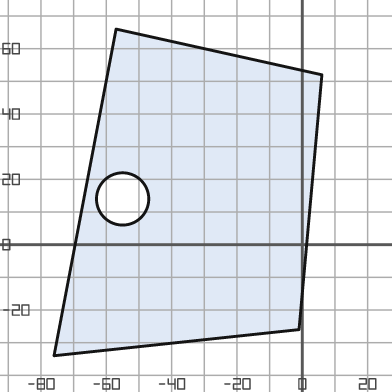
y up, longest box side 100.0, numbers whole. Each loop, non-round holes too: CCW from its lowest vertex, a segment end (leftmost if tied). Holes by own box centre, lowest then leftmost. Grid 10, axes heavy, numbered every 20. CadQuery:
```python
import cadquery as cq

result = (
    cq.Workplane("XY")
    .moveTo(-76.0, -34.0)
    .lineTo(-1.0, -26.0)
    .lineTo(6.0, 52.0)
    .lineTo(-57.0, 66.0)
    .close()
    .moveTo(-55.0, 14.0)
    .circle(8.0)
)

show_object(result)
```